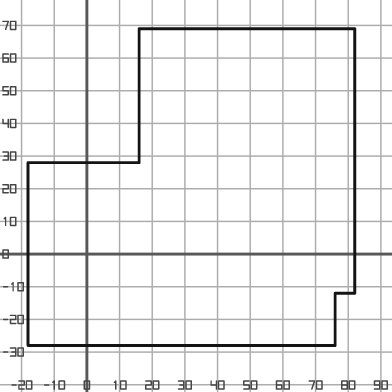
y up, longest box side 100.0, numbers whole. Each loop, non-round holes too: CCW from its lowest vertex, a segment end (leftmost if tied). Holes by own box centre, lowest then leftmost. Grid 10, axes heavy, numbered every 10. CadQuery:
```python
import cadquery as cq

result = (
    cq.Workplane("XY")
    .moveTo(-18.0, -28.0)
    .lineTo(76.0, -28.0)
    .lineTo(76.0, -12.0)
    .lineTo(82.0, -12.0)
    .lineTo(82.0, 69.0)
    .lineTo(16.0, 69.0)
    .lineTo(16.0, 28.0)
    .lineTo(-18.0, 28.0)
    .close()
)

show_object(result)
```